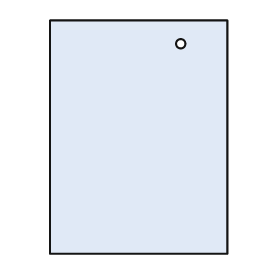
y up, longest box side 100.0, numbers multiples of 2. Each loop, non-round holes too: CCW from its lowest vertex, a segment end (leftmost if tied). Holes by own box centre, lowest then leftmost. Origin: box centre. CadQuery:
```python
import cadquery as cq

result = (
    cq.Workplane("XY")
    .moveTo(-38.0, -50.0)
    .lineTo(38.0, -50.0)
    .lineTo(38.0, 50.0)
    .lineTo(-38.0, 50.0)
    .close()
    .moveTo(18.0, 40.0)
    .circle(2.0)
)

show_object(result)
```